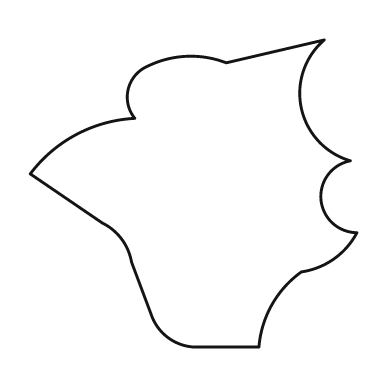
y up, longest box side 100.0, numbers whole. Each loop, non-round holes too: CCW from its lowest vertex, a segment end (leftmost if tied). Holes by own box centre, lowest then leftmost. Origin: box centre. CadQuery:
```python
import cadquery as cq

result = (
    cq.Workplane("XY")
    .moveTo(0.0, -47.0)
    .lineTo(20.0, -47.0)
    .threePointArc((24.0, -34.0), (33.0, -24.0))
    .threePointArc((43.0, -20.0), (50.0, -12.0))
    .threePointArc((39.0, -2.0), (48.0, 10.0))
    .threePointArc((33.0, 26.0), (40.0, 47.0))
    .lineTo(10.0, 40.0)
    .threePointArc((-2.0, 42.0), (-14.0, 39.0))
    .threePointArc((-20.0, 32.0), (-18.0, 23.0))
    .threePointArc((-36.0, 18.0), (-50.0, 6.0))
    .lineTo(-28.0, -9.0)
    .threePointArc((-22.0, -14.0), (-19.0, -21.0))
    .lineTo(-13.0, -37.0)
    .threePointArc((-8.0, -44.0), (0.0, -47.0))
    .close()
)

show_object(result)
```